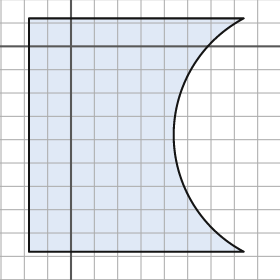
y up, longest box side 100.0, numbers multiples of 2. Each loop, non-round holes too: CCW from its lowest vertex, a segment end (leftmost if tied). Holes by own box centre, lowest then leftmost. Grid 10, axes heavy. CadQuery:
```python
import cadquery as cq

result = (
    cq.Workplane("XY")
    .moveTo(-18.0, -88.0)
    .lineTo(74.0, -88.0)
    .threePointArc((44.0, -38.0), (74.0, 12.0))
    .lineTo(-18.0, 12.0)
    .close()
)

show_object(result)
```